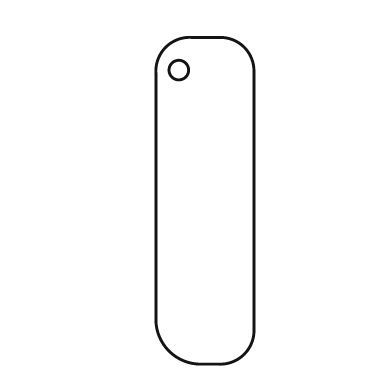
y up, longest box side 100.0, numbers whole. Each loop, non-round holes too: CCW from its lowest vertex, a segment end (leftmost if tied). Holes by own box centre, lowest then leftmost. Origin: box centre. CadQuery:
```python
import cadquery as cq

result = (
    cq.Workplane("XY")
    .moveTo(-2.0, -50.0)
    .lineTo(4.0, -50.0)
    .threePointArc((12.0, -47.0), (15.0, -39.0))
    .lineTo(15.0, 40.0)
    .threePointArc((12.0, 47.0), (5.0, 50.0))
    .lineTo(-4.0, 50.0)
    .threePointArc((-12.0, 47.0), (-15.0, 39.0))
    .lineTo(-15.0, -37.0)
    .threePointArc((-11.0, -46.0), (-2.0, -50.0))
    .close()
    .moveTo(-8.0, 40.0)
    .circle(3.0)
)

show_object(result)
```